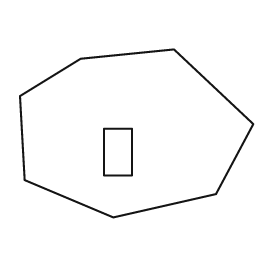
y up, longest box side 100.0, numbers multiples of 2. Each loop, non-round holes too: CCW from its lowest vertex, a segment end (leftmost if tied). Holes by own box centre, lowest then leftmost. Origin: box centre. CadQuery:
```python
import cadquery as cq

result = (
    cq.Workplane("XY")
    .moveTo(-10.0, -36.0)
    .lineTo(34.0, -26.0)
    .lineTo(50.0, 4.0)
    .lineTo(16.0, 36.0)
    .lineTo(-24.0, 32.0)
    .lineTo(-50.0, 16.0)
    .lineTo(-48.0, -20.0)
    .close()
    .moveTo(-14.0, -18.0)
    .lineTo(-2.0, -18.0)
    .lineTo(-2.0, 2.0)
    .lineTo(-14.0, 2.0)
    .close()
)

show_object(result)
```